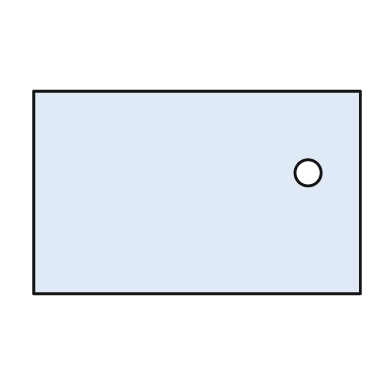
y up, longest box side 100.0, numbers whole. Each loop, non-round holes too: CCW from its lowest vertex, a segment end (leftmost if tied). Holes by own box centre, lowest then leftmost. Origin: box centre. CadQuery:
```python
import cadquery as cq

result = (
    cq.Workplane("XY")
    .moveTo(-50.0, -31.0)
    .lineTo(50.0, -31.0)
    .lineTo(50.0, 31.0)
    .lineTo(-50.0, 31.0)
    .close()
    .moveTo(34.0, 6.0)
    .circle(4.0)
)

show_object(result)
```